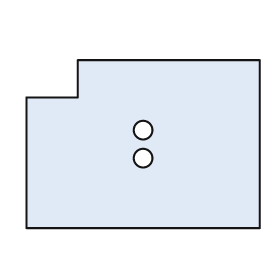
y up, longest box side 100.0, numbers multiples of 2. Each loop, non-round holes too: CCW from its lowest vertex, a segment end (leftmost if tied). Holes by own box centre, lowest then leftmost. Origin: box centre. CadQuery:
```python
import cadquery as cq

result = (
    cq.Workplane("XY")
    .moveTo(-50.0, -36.0)
    .lineTo(50.0, -36.0)
    .lineTo(50.0, 36.0)
    .lineTo(-28.0, 36.0)
    .lineTo(-28.0, 20.0)
    .lineTo(-50.0, 20.0)
    .close()
    .moveTo(0.0, -6.0)
    .circle(4.0)
    .moveTo(0.0, 6.0)
    .circle(4.0)
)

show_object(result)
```